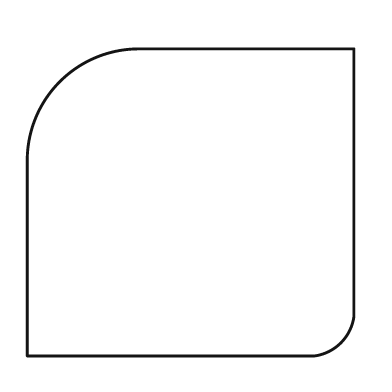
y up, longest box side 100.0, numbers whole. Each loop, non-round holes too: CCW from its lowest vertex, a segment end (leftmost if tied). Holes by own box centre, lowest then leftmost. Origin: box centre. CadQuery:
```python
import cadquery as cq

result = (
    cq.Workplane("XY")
    .moveTo(-50.0, -47.0)
    .lineTo(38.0, -47.0)
    .threePointArc((46.0, -43.0), (50.0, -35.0))
    .lineTo(50.0, 47.0)
    .lineTo(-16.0, 47.0)
    .threePointArc((-40.0, 37.0), (-50.0, 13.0))
    .close()
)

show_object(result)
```